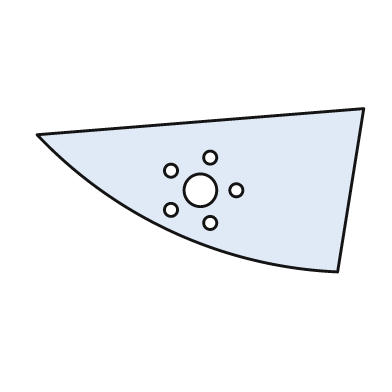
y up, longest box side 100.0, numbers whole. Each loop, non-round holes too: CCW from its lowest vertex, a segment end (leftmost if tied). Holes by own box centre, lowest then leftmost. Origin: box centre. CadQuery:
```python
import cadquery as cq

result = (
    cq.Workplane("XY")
    .moveTo(42.0, -25.0)
    .lineTo(50.0, 25.0)
    .lineTo(-50.0, 17.0)
    .threePointArc((-8.0, -13.0), (42.0, -25.0))
    .close()
    .moveTo(3.0, -10.0)
    .circle(2.0)
    .moveTo(-9.0, -6.0)
    .circle(2.0)
    .moveTo(0.0, 0.0)
    .circle(5.0)
    .moveTo(11.0, 0.0)
    .circle(2.0)
    .moveTo(-9.0, 6.0)
    .circle(2.0)
    .moveTo(3.0, 10.0)
    .circle(2.0)
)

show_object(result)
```